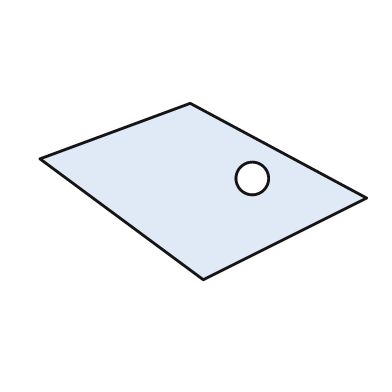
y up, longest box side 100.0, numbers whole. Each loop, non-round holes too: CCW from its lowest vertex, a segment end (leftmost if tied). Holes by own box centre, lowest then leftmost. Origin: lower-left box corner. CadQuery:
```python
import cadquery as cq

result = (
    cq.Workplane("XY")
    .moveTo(50.0, 0.0)
    .lineTo(100.0, 25.0)
    .lineTo(46.0, 54.0)
    .lineTo(0.0, 37.0)
    .close()
    .moveTo(65.0, 31.0)
    .circle(5.0)
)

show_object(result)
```